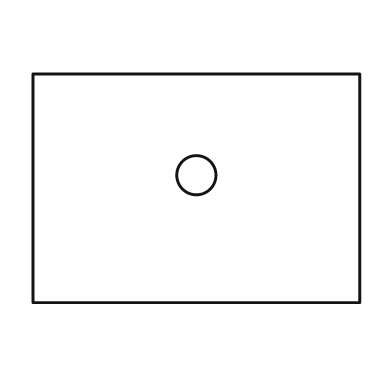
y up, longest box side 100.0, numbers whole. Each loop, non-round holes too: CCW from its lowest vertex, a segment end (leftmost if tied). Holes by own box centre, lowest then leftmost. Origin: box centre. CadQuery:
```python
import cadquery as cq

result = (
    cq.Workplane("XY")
    .moveTo(-50.0, -35.0)
    .lineTo(50.0, -35.0)
    .lineTo(50.0, 35.0)
    .lineTo(-50.0, 35.0)
    .close()
    .moveTo(0.0, 4.0)
    .circle(6.0)
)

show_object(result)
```